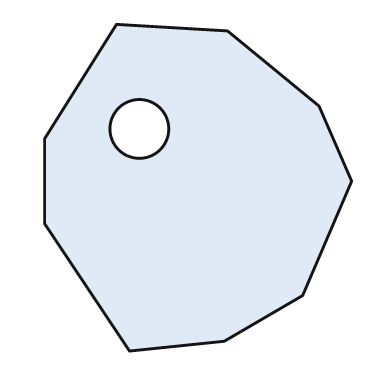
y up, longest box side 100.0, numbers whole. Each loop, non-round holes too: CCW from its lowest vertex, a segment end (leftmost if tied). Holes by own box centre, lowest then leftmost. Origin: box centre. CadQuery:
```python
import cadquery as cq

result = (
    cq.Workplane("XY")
    .moveTo(-21.0, -50.0)
    .lineTo(8.0, -47.0)
    .lineTo(32.0, -33.0)
    .lineTo(47.0, 2.0)
    .lineTo(37.0, 25.0)
    .lineTo(9.0, 48.0)
    .lineTo(-25.0, 50.0)
    .lineTo(-47.0, 15.0)
    .lineTo(-47.0, -11.0)
    .close()
    .moveTo(-18.0, 18.0)
    .circle(9.0)
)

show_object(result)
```